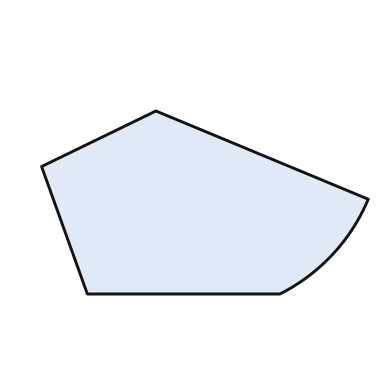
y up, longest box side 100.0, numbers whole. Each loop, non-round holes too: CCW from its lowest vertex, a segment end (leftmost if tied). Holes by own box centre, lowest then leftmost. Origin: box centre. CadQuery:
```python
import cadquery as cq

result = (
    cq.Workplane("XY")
    .moveTo(-36.0, -28.0)
    .lineTo(23.0, -28.0)
    .threePointArc((39.0, -16.0), (50.0, 1.0))
    .lineTo(-15.0, 28.0)
    .lineTo(-50.0, 11.0)
    .close()
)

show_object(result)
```